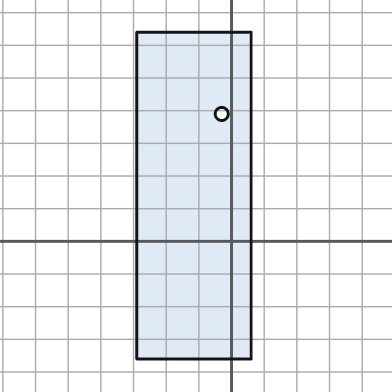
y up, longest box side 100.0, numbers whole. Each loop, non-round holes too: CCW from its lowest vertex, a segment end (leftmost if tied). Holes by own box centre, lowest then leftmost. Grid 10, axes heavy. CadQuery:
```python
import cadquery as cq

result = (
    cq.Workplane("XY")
    .moveTo(-29.0, -36.0)
    .lineTo(6.0, -36.0)
    .lineTo(6.0, 64.0)
    .lineTo(-29.0, 64.0)
    .close()
    .moveTo(-3.0, 39.0)
    .circle(2.0)
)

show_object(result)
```